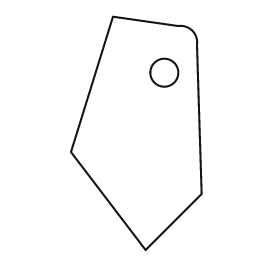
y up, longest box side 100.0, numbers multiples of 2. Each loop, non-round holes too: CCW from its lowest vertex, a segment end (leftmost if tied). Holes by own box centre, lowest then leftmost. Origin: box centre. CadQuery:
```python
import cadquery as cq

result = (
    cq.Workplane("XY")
    .moveTo(4.0, -50.0)
    .lineTo(28.0, -26.0)
    .lineTo(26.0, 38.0)
    .threePointArc((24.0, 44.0), (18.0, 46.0))
    .lineTo(-10.0, 50.0)
    .lineTo(-28.0, -8.0)
    .close()
    .moveTo(12.0, 26.0)
    .circle(6.0)
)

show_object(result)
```